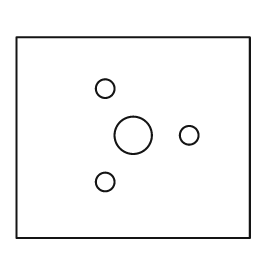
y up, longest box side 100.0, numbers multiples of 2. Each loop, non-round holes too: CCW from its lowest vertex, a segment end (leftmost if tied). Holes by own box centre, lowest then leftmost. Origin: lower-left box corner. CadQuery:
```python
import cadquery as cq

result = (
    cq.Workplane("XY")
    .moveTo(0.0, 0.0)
    .lineTo(100.0, 0.0)
    .lineTo(100.0, 86.0)
    .lineTo(0.0, 86.0)
    .close()
    .moveTo(38.0, 24.0)
    .circle(4.0)
    .moveTo(50.0, 44.0)
    .circle(8.0)
    .moveTo(74.0, 44.0)
    .circle(4.0)
    .moveTo(38.0, 64.0)
    .circle(4.0)
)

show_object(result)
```